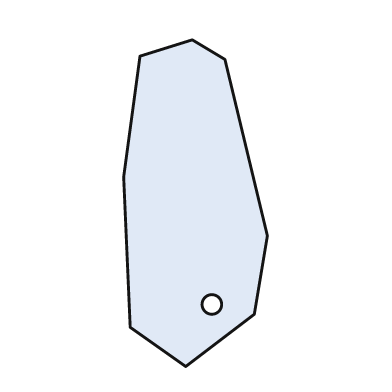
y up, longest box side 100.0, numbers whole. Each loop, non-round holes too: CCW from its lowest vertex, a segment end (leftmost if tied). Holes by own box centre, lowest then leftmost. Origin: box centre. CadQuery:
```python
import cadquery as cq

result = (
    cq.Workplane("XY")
    .moveTo(-3.0, -50.0)
    .lineTo(18.0, -34.0)
    .lineTo(22.0, -10.0)
    .lineTo(9.0, 44.0)
    .lineTo(-1.0, 50.0)
    .lineTo(-17.0, 45.0)
    .lineTo(-22.0, 8.0)
    .lineTo(-20.0, -38.0)
    .close()
    .moveTo(5.0, -31.0)
    .circle(3.0)
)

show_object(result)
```